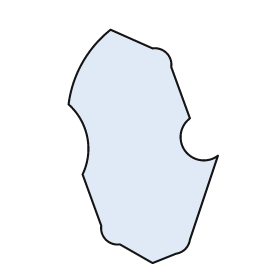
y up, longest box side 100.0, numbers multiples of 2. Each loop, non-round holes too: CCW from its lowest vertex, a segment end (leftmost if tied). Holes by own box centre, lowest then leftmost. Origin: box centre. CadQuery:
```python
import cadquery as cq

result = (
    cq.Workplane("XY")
    .moveTo(4.0, -50.0)
    .lineTo(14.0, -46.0)
    .threePointArc((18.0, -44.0), (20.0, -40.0))
    .lineTo(32.0, -4.0)
    .threePointArc((18.0, -2.0), (20.0, 12.0))
    .lineTo(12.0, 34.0)
    .threePointArc((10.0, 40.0), (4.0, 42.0))
    .lineTo(-14.0, 50.0)
    .threePointArc((-26.0, 36.0), (-32.0, 18.0))
    .threePointArc((-24.0, 4.0), (-26.0, -12.0))
    .lineTo(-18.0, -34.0)
    .threePointArc((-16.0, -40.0), (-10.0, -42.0))
    .close()
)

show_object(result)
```